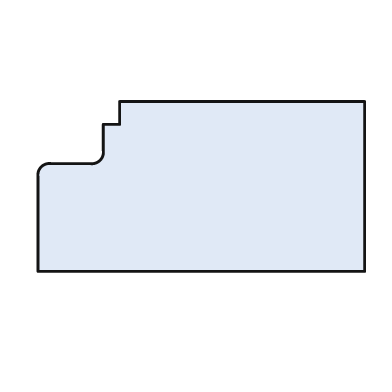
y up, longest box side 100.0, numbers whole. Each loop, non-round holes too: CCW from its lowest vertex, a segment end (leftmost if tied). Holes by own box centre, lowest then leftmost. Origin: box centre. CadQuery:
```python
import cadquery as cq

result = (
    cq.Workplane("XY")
    .moveTo(-50.0, -26.0)
    .lineTo(50.0, -26.0)
    .lineTo(50.0, 26.0)
    .lineTo(-25.0, 26.0)
    .lineTo(-25.0, 19.0)
    .lineTo(-30.0, 19.0)
    .lineTo(-30.0, 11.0)
    .threePointArc((-31.0, 8.0), (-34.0, 7.0))
    .lineTo(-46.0, 7.0)
    .threePointArc((-49.0, 6.0), (-50.0, 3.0))
    .close()
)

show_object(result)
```